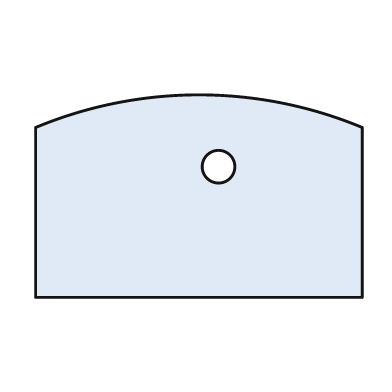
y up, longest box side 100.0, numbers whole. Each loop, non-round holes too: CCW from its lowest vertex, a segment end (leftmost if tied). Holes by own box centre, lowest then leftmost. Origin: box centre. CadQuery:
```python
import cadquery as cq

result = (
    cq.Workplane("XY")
    .moveTo(-50.0, -31.0)
    .lineTo(50.0, -31.0)
    .lineTo(50.0, 21.0)
    .threePointArc((0.0, 31.0), (-50.0, 21.0))
    .close()
    .moveTo(6.0, 9.0)
    .circle(5.0)
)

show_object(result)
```